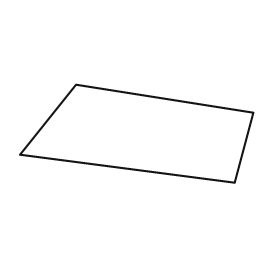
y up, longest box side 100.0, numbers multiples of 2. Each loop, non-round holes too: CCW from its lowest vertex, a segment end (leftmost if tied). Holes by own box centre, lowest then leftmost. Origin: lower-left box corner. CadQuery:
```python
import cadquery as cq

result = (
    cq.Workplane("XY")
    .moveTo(92.0, 0.0)
    .lineTo(100.0, 30.0)
    .lineTo(24.0, 42.0)
    .lineTo(0.0, 12.0)
    .close()
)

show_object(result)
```